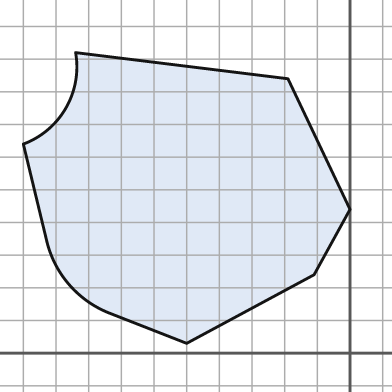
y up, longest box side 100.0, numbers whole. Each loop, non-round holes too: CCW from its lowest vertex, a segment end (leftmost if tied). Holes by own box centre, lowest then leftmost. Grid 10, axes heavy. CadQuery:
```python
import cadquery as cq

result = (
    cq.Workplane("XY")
    .moveTo(-50.0, 3.0)
    .lineTo(-11.0, 24.0)
    .lineTo(0.0, 44.0)
    .lineTo(-19.0, 84.0)
    .lineTo(-84.0, 92.0)
    .threePointArc((-87.0, 75.0), (-100.0, 64.0))
    .lineTo(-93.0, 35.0)
    .threePointArc((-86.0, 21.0), (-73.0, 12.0))
    .close()
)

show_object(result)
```